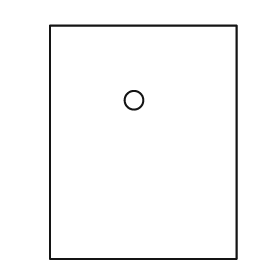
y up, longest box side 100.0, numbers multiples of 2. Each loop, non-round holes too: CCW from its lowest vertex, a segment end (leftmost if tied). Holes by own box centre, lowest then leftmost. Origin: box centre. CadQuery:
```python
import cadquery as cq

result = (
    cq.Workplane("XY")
    .moveTo(-40.0, -50.0)
    .lineTo(40.0, -50.0)
    .lineTo(40.0, 50.0)
    .lineTo(-40.0, 50.0)
    .close()
    .moveTo(-4.0, 18.0)
    .circle(4.0)
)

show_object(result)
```